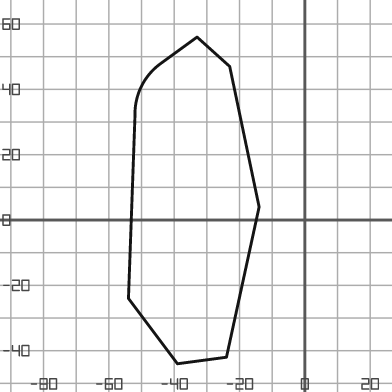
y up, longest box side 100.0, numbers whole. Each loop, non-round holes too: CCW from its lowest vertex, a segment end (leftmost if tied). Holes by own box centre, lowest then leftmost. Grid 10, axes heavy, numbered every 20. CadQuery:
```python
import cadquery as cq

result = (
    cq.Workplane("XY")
    .moveTo(-39.0, -44.0)
    .lineTo(-24.0, -42.0)
    .lineTo(-14.0, 4.0)
    .lineTo(-23.0, 47.0)
    .lineTo(-33.0, 56.0)
    .lineTo(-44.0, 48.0)
    .threePointArc((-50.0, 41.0), (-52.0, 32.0))
    .lineTo(-54.0, -24.0)
    .close()
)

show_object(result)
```